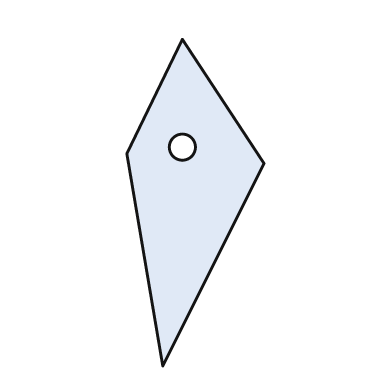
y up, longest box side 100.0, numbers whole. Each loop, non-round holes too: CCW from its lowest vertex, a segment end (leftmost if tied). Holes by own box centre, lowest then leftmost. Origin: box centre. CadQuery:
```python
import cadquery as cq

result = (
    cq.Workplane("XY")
    .moveTo(-10.0, -50.0)
    .lineTo(21.0, 12.0)
    .lineTo(-4.0, 50.0)
    .lineTo(-21.0, 15.0)
    .close()
    .moveTo(-4.0, 17.0)
    .circle(4.0)
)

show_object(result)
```